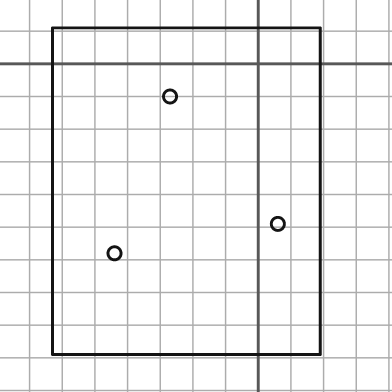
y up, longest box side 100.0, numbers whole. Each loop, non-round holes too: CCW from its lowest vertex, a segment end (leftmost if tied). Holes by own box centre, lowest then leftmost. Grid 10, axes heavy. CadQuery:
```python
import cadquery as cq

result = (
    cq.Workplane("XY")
    .moveTo(-63.0, -89.0)
    .lineTo(19.0, -89.0)
    .lineTo(19.0, 11.0)
    .lineTo(-63.0, 11.0)
    .close()
    .moveTo(-44.0, -58.0)
    .circle(2.0)
    .moveTo(6.0, -49.0)
    .circle(2.0)
    .moveTo(-27.0, -10.0)
    .circle(2.0)
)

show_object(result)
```